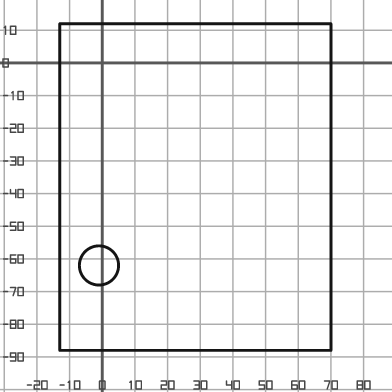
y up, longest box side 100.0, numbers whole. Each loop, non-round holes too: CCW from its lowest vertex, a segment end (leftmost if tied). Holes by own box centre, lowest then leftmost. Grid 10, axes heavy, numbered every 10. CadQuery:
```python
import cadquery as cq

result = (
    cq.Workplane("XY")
    .moveTo(-13.0, -88.0)
    .lineTo(70.0, -88.0)
    .lineTo(70.0, 12.0)
    .lineTo(-13.0, 12.0)
    .close()
    .moveTo(-1.0, -62.0)
    .circle(6.0)
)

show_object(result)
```